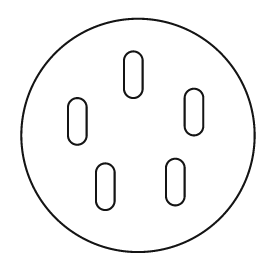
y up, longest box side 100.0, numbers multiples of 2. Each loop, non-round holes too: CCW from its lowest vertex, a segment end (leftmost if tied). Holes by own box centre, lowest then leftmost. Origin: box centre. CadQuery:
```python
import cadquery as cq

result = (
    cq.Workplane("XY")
    .moveTo(0.0, 0.0)
    .circle(50.0)
    .moveTo(-18.0, -28.0)
    .threePointArc((-14.0, -32.0), (-10.0, -28.0))
    .lineTo(-10.0, -16.0)
    .threePointArc((-14.0, -12.0), (-18.0, -16.0))
    .close()
    .moveTo(12.0, -26.0)
    .threePointArc((16.0, -30.0), (20.0, -26.0))
    .lineTo(20.0, -14.0)
    .threePointArc((16.0, -10.0), (12.0, -14.0))
    .close()
    .moveTo(-30.0, 0.0)
    .threePointArc((-26.0, -4.0), (-22.0, 0.0))
    .lineTo(-22.0, 12.0)
    .threePointArc((-26.0, 16.0), (-30.0, 12.0))
    .close()
    .moveTo(20.0, 4.0)
    .threePointArc((24.0, 0.0), (28.0, 4.0))
    .lineTo(28.0, 16.0)
    .threePointArc((24.0, 20.0), (20.0, 16.0))
    .close()
    .moveTo(-6.0, 20.0)
    .threePointArc((-2.0, 16.0), (2.0, 20.0))
    .lineTo(2.0, 32.0)
    .threePointArc((-2.0, 36.0), (-6.0, 32.0))
    .close()
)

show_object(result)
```